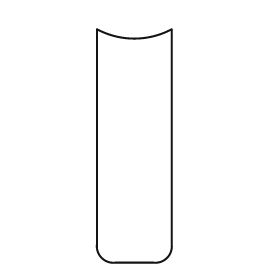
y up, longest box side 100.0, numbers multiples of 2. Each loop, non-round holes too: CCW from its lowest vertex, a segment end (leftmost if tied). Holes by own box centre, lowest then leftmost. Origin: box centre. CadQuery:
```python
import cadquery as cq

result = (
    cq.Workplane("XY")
    .moveTo(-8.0, -50.0)
    .lineTo(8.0, -50.0)
    .threePointArc((14.0, -48.0), (16.0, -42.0))
    .lineTo(16.0, 50.0)
    .threePointArc((0.0, 46.0), (-16.0, 50.0))
    .lineTo(-16.0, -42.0)
    .threePointArc((-14.0, -48.0), (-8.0, -50.0))
    .close()
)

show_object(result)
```